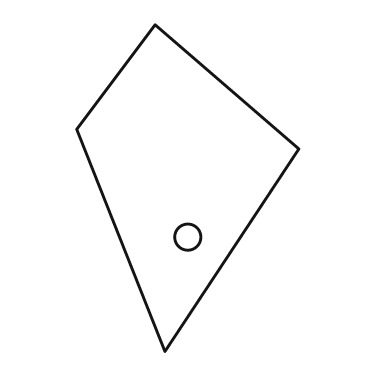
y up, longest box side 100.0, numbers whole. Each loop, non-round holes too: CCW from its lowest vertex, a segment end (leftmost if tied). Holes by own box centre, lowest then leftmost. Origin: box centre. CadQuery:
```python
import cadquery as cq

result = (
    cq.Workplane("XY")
    .moveTo(-7.0, -50.0)
    .lineTo(34.0, 12.0)
    .lineTo(-10.0, 50.0)
    .lineTo(-34.0, 18.0)
    .close()
    .moveTo(0.0, -15.0)
    .circle(4.0)
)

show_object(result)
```